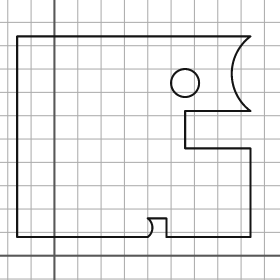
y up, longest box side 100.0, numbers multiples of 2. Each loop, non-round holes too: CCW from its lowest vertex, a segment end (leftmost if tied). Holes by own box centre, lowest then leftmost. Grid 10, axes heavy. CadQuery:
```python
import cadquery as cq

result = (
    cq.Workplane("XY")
    .moveTo(-16.0, 8.0)
    .lineTo(40.0, 8.0)
    .threePointArc((42.0, 12.0), (40.0, 16.0))
    .lineTo(48.0, 16.0)
    .lineTo(48.0, 8.0)
    .lineTo(84.0, 8.0)
    .lineTo(84.0, 46.0)
    .lineTo(56.0, 46.0)
    .lineTo(56.0, 62.0)
    .lineTo(84.0, 62.0)
    .threePointArc((76.0, 78.0), (84.0, 94.0))
    .lineTo(-16.0, 94.0)
    .close()
    .moveTo(56.0, 74.0)
    .circle(6.0)
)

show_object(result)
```